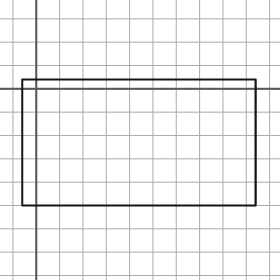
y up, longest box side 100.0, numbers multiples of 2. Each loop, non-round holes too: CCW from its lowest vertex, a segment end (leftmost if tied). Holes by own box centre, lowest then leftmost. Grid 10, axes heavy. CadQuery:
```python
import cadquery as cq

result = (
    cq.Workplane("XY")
    .moveTo(-6.0, -50.0)
    .lineTo(94.0, -50.0)
    .lineTo(94.0, 4.0)
    .lineTo(-6.0, 4.0)
    .close()
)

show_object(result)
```